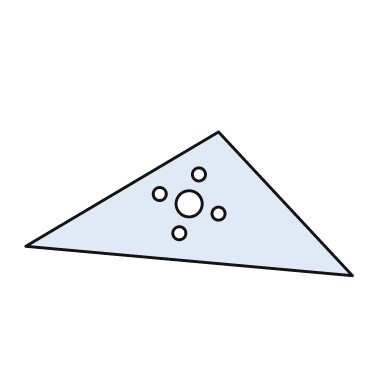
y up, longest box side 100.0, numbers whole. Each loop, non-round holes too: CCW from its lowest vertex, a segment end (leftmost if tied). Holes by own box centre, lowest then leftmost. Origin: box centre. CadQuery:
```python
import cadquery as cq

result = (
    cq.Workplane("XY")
    .moveTo(50.0, -22.0)
    .lineTo(9.0, 22.0)
    .lineTo(-50.0, -13.0)
    .close()
    .moveTo(-3.0, -9.0)
    .circle(2.0)
    .moveTo(9.0, -3.0)
    .circle(2.0)
    .moveTo(0.0, 0.0)
    .circle(4.0)
    .moveTo(-9.0, 3.0)
    .circle(2.0)
    .moveTo(3.0, 9.0)
    .circle(2.0)
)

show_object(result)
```